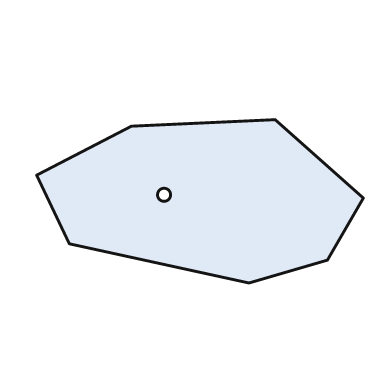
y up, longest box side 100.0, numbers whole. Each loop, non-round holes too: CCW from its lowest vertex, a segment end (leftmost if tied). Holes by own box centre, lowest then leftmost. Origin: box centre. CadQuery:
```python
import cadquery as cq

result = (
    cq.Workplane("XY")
    .moveTo(15.0, -25.0)
    .lineTo(39.0, -18.0)
    .lineTo(50.0, 1.0)
    .lineTo(23.0, 25.0)
    .lineTo(-21.0, 23.0)
    .lineTo(-50.0, 8.0)
    .lineTo(-40.0, -13.0)
    .close()
    .moveTo(-11.0, 2.0)
    .circle(2.0)
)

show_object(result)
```